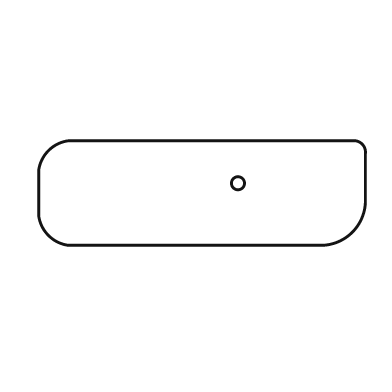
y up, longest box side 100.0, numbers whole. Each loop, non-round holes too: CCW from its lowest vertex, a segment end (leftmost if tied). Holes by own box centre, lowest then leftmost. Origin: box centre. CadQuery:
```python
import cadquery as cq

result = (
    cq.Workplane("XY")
    .moveTo(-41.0, -16.0)
    .lineTo(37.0, -16.0)
    .threePointArc((46.0, -12.0), (50.0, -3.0))
    .lineTo(50.0, 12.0)
    .threePointArc((49.0, 15.0), (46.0, 16.0))
    .lineTo(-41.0, 16.0)
    .threePointArc((-47.0, 13.0), (-50.0, 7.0))
    .lineTo(-50.0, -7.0)
    .threePointArc((-47.0, -13.0), (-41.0, -16.0))
    .close()
    .moveTo(11.0, 3.0)
    .circle(2.0)
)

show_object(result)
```